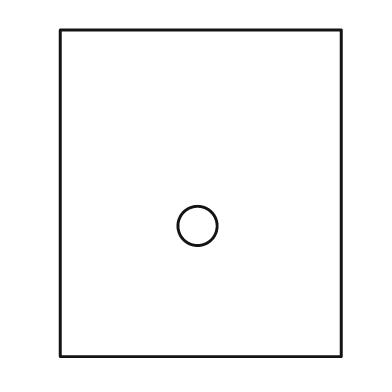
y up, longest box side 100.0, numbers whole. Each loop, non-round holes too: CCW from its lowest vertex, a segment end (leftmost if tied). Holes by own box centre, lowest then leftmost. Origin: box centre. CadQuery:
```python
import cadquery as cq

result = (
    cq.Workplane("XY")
    .moveTo(-43.0, -50.0)
    .lineTo(43.0, -50.0)
    .lineTo(43.0, 50.0)
    .lineTo(-43.0, 50.0)
    .close()
    .moveTo(-1.0, -10.0)
    .circle(6.0)
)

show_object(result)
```